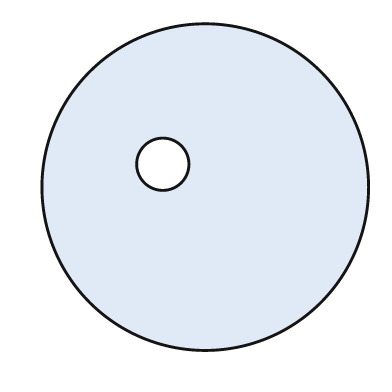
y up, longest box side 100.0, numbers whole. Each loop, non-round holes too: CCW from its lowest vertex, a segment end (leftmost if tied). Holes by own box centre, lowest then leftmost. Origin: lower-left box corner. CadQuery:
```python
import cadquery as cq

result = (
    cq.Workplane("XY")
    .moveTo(50.0, 50.0)
    .circle(50.0)
    .moveTo(37.0, 57.0)
    .circle(8.0)
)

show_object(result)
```